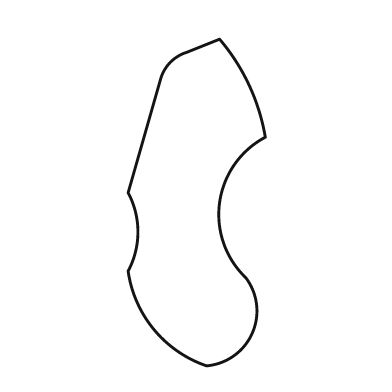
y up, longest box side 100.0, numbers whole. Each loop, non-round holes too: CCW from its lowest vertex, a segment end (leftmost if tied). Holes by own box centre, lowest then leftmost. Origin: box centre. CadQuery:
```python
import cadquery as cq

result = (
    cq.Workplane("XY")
    .moveTo(3.0, -50.0)
    .threePointArc((17.0, -40.0), (15.0, -23.0))
    .threePointArc((7.0, 0.0), (21.0, 20.0))
    .threePointArc((16.0, 36.0), (7.0, 50.0))
    .lineTo(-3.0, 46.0)
    .threePointArc((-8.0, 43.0), (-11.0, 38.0))
    .lineTo(-21.0, 3.0)
    .threePointArc((-18.0, -9.0), (-21.0, -21.0))
    .threePointArc((-13.0, -39.0), (3.0, -50.0))
    .close()
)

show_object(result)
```